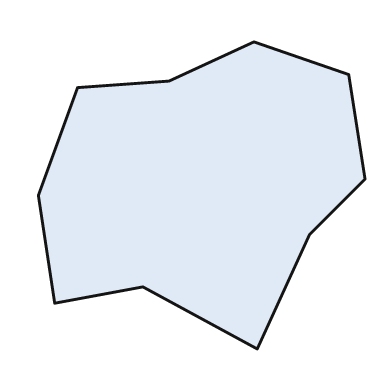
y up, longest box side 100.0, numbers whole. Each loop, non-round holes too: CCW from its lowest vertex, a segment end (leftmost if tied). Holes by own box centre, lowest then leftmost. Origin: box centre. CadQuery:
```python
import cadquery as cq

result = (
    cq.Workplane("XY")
    .moveTo(17.0, -47.0)
    .lineTo(33.0, -12.0)
    .lineTo(50.0, 5.0)
    .lineTo(45.0, 37.0)
    .lineTo(16.0, 47.0)
    .lineTo(-10.0, 35.0)
    .lineTo(-38.0, 33.0)
    .lineTo(-50.0, 0.0)
    .lineTo(-45.0, -33.0)
    .lineTo(-18.0, -28.0)
    .close()
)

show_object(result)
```